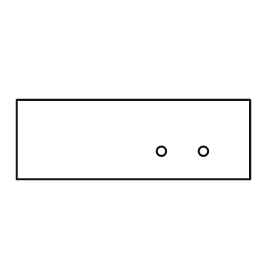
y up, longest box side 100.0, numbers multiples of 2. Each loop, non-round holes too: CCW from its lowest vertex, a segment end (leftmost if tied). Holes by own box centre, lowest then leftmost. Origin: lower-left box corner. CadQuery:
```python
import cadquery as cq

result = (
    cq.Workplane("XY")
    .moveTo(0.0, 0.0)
    .lineTo(100.0, 0.0)
    .lineTo(100.0, 34.0)
    .lineTo(0.0, 34.0)
    .close()
    .moveTo(62.0, 12.0)
    .circle(2.0)
    .moveTo(80.0, 12.0)
    .circle(2.0)
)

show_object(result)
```